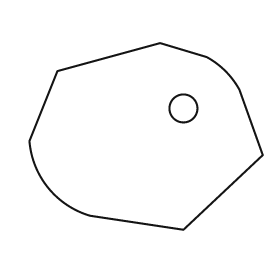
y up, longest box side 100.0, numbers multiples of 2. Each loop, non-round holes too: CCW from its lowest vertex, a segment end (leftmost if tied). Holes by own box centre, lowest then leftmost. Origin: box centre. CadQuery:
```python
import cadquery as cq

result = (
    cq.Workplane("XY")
    .moveTo(16.0, -40.0)
    .lineTo(50.0, -8.0)
    .lineTo(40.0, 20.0)
    .threePointArc((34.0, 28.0), (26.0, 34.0))
    .lineTo(6.0, 40.0)
    .lineTo(-38.0, 28.0)
    .lineTo(-50.0, -2.0)
    .threePointArc((-42.0, -22.0), (-24.0, -34.0))
    .close()
    .moveTo(16.0, 12.0)
    .circle(6.0)
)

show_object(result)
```